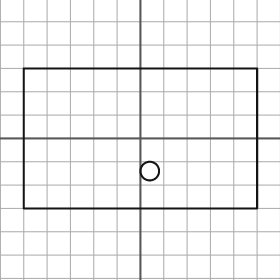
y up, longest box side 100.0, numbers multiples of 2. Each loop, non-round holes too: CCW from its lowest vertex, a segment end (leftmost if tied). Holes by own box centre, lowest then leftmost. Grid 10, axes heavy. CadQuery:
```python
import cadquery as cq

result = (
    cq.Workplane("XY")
    .moveTo(-50.0, -30.0)
    .lineTo(50.0, -30.0)
    .lineTo(50.0, 30.0)
    .lineTo(-50.0, 30.0)
    .close()
    .moveTo(4.0, -14.0)
    .circle(4.0)
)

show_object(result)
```